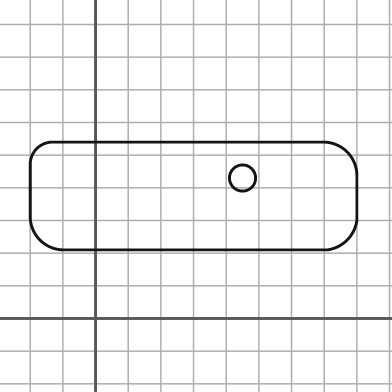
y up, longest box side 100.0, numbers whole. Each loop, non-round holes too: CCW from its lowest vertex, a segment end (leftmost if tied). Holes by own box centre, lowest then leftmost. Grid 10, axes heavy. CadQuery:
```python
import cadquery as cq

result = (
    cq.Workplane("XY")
    .moveTo(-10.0, 21.0)
    .lineTo(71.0, 21.0)
    .threePointArc((77.0, 24.0), (80.0, 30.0))
    .lineTo(80.0, 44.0)
    .threePointArc((77.0, 51.0), (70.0, 54.0))
    .lineTo(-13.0, 54.0)
    .threePointArc((-18.0, 52.0), (-20.0, 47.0))
    .lineTo(-20.0, 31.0)
    .threePointArc((-17.0, 24.0), (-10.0, 21.0))
    .close()
    .moveTo(45.0, 43.0)
    .circle(4.0)
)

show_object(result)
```